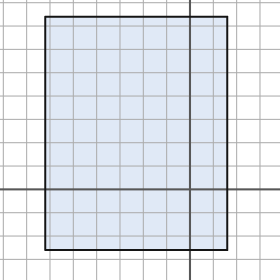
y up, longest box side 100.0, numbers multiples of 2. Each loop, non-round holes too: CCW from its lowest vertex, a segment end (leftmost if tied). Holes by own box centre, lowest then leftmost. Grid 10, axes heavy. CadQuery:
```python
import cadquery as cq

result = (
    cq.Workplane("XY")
    .moveTo(-62.0, -26.0)
    .lineTo(16.0, -26.0)
    .lineTo(16.0, 74.0)
    .lineTo(-62.0, 74.0)
    .close()
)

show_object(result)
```